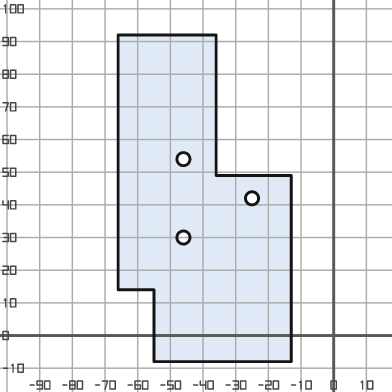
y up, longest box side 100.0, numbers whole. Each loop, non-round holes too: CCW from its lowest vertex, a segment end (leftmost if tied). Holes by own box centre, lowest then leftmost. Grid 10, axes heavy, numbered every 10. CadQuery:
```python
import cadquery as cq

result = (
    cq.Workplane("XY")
    .moveTo(-55.0, -8.0)
    .lineTo(-13.0, -8.0)
    .lineTo(-13.0, 49.0)
    .lineTo(-36.0, 49.0)
    .lineTo(-36.0, 92.0)
    .lineTo(-66.0, 92.0)
    .lineTo(-66.0, 14.0)
    .lineTo(-55.0, 14.0)
    .close()
    .moveTo(-46.0, 30.0)
    .circle(2.0)
    .moveTo(-25.0, 42.0)
    .circle(2.0)
    .moveTo(-46.0, 54.0)
    .circle(2.0)
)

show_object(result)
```